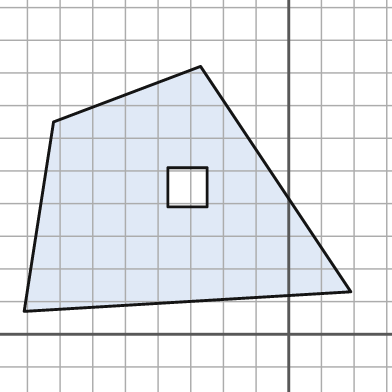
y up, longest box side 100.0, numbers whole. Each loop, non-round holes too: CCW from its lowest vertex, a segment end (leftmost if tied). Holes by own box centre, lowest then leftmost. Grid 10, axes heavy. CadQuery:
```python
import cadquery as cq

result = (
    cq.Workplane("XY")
    .moveTo(-81.0, 7.0)
    .lineTo(19.0, 13.0)
    .lineTo(-27.0, 82.0)
    .lineTo(-72.0, 65.0)
    .close()
    .moveTo(-37.0, 39.0)
    .lineTo(-25.0, 39.0)
    .lineTo(-25.0, 51.0)
    .lineTo(-37.0, 51.0)
    .close()
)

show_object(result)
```